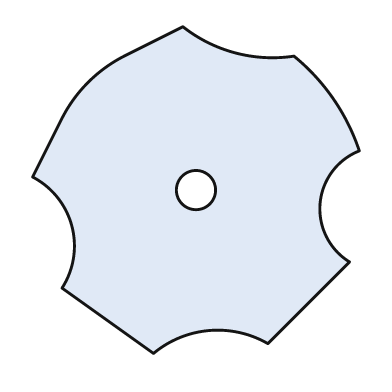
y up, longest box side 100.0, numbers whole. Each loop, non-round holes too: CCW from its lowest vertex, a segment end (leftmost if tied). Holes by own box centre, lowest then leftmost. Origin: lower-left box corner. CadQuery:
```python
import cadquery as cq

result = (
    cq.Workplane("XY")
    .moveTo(37.0, 0.0)
    .threePointArc((54.0, 7.0), (72.0, 3.0))
    .lineTo(97.0, 28.0)
    .threePointArc((88.0, 46.0), (100.0, 62.0))
    .threePointArc((92.0, 78.0), (80.0, 91.0))
    .threePointArc((62.0, 92.0), (46.0, 100.0))
    .lineTo(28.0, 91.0)
    .threePointArc((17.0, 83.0), (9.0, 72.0))
    .lineTo(0.0, 54.0)
    .threePointArc((12.0, 39.0), (9.0, 20.0))
    .close()
    .moveTo(50.0, 50.0)
    .circle(6.0)
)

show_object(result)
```